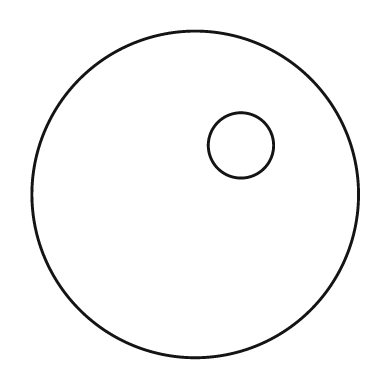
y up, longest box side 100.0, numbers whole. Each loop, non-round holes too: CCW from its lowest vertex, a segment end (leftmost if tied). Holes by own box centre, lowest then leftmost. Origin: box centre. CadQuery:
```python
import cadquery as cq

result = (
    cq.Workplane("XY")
    .moveTo(0.0, 0.0)
    .circle(50.0)
    .moveTo(14.0, 15.0)
    .circle(10.0)
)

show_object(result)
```